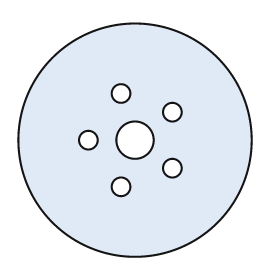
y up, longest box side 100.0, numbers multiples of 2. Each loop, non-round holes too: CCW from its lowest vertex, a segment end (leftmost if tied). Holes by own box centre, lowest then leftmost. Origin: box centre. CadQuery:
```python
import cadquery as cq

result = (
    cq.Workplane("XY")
    .moveTo(0.0, 0.0)
    .circle(50.0)
    .moveTo(-6.0, -20.0)
    .circle(4.0)
    .moveTo(16.0, -12.0)
    .circle(4.0)
    .moveTo(-20.0, 0.0)
    .circle(4.0)
    .moveTo(0.0, 0.0)
    .circle(8.0)
    .moveTo(16.0, 12.0)
    .circle(4.0)
    .moveTo(-6.0, 20.0)
    .circle(4.0)
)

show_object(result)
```